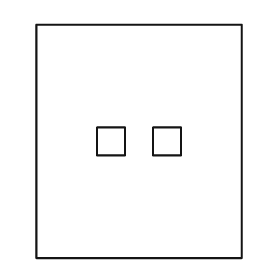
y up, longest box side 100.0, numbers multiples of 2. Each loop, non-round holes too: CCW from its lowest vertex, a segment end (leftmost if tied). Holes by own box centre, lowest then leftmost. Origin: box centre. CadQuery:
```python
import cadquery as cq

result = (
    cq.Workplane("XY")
    .moveTo(-44.0, -50.0)
    .lineTo(44.0, -50.0)
    .lineTo(44.0, 50.0)
    .lineTo(-44.0, 50.0)
    .close()
    .moveTo(-18.0, -6.0)
    .lineTo(-6.0, -6.0)
    .lineTo(-6.0, 6.0)
    .lineTo(-18.0, 6.0)
    .close()
    .moveTo(6.0, -6.0)
    .lineTo(18.0, -6.0)
    .lineTo(18.0, 6.0)
    .lineTo(6.0, 6.0)
    .close()
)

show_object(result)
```